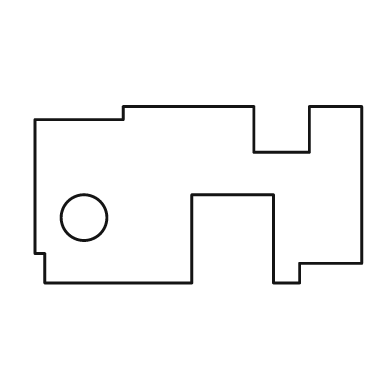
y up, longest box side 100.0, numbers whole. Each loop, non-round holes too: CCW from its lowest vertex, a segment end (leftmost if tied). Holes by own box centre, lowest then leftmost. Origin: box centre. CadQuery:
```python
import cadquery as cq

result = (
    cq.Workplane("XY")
    .moveTo(-47.0, -27.0)
    .lineTo(-2.0, -27.0)
    .lineTo(-2.0, 0.0)
    .lineTo(23.0, 0.0)
    .lineTo(23.0, -27.0)
    .lineTo(31.0, -27.0)
    .lineTo(31.0, -21.0)
    .lineTo(50.0, -21.0)
    .lineTo(50.0, 27.0)
    .lineTo(34.0, 27.0)
    .lineTo(34.0, 13.0)
    .lineTo(17.0, 13.0)
    .lineTo(17.0, 27.0)
    .lineTo(-23.0, 27.0)
    .lineTo(-23.0, 23.0)
    .lineTo(-50.0, 23.0)
    .lineTo(-50.0, -18.0)
    .lineTo(-47.0, -18.0)
    .close()
    .moveTo(-35.0, -7.0)
    .circle(7.0)
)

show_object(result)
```